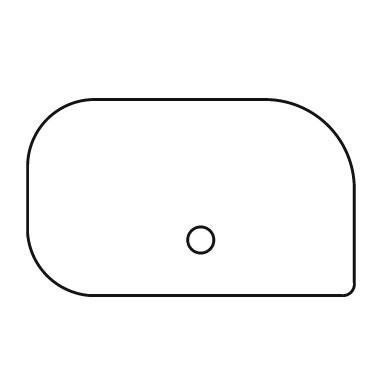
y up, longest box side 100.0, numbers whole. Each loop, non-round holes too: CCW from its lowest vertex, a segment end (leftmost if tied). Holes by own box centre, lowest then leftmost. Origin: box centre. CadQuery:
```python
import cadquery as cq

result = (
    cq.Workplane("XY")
    .moveTo(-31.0, -30.0)
    .lineTo(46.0, -30.0)
    .threePointArc((49.0, -29.0), (50.0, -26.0))
    .lineTo(50.0, 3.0)
    .threePointArc((42.0, 22.0), (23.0, 30.0))
    .lineTo(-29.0, 30.0)
    .threePointArc((-44.0, 24.0), (-50.0, 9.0))
    .lineTo(-50.0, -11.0)
    .threePointArc((-44.0, -24.0), (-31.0, -30.0))
    .close()
    .moveTo(3.0, -13.0)
    .circle(4.0)
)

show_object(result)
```